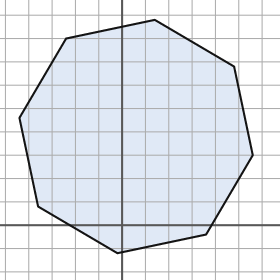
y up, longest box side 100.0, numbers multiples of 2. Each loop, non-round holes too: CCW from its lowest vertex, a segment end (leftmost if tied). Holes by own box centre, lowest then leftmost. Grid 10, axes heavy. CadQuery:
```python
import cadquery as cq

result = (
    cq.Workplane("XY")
    .moveTo(-2.0, -12.0)
    .lineTo(36.0, -4.0)
    .lineTo(56.0, 30.0)
    .lineTo(48.0, 68.0)
    .lineTo(14.0, 88.0)
    .lineTo(-24.0, 80.0)
    .lineTo(-44.0, 46.0)
    .lineTo(-36.0, 8.0)
    .close()
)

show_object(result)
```